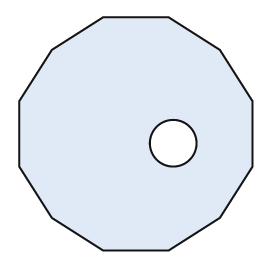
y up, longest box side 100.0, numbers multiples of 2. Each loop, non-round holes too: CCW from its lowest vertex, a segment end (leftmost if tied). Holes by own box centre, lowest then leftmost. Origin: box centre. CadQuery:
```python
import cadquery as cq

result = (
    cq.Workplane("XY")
    .moveTo(-14.0, -50.0)
    .lineTo(14.0, -50.0)
    .lineTo(36.0, -36.0)
    .lineTo(50.0, -14.0)
    .lineTo(50.0, 14.0)
    .lineTo(36.0, 36.0)
    .lineTo(14.0, 50.0)
    .lineTo(-14.0, 50.0)
    .lineTo(-36.0, 36.0)
    .lineTo(-50.0, 14.0)
    .lineTo(-50.0, -14.0)
    .lineTo(-36.0, -36.0)
    .close()
    .moveTo(16.0, -4.0)
    .circle(10.0)
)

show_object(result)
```